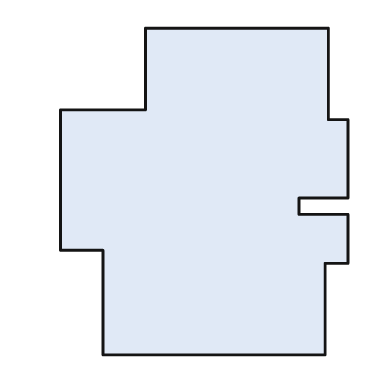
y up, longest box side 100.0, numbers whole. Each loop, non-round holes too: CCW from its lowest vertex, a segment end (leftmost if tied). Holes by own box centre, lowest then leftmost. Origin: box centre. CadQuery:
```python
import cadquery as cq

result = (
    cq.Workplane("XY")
    .moveTo(-31.0, -50.0)
    .lineTo(37.0, -50.0)
    .lineTo(37.0, -22.0)
    .lineTo(44.0, -22.0)
    .lineTo(44.0, -7.0)
    .lineTo(29.0, -7.0)
    .lineTo(29.0, -2.0)
    .lineTo(44.0, -2.0)
    .lineTo(44.0, 22.0)
    .lineTo(38.0, 22.0)
    .lineTo(38.0, 50.0)
    .lineTo(-18.0, 50.0)
    .lineTo(-18.0, 25.0)
    .lineTo(-44.0, 25.0)
    .lineTo(-44.0, -18.0)
    .lineTo(-31.0, -18.0)
    .close()
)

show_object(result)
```